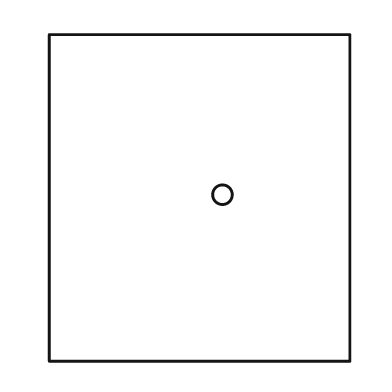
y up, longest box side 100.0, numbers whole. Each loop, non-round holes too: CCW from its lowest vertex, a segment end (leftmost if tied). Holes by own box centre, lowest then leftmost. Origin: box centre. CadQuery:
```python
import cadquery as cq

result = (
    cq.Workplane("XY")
    .moveTo(-46.0, -50.0)
    .lineTo(46.0, -50.0)
    .lineTo(46.0, 50.0)
    .lineTo(-46.0, 50.0)
    .close()
    .moveTo(7.0, 1.0)
    .circle(3.0)
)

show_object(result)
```